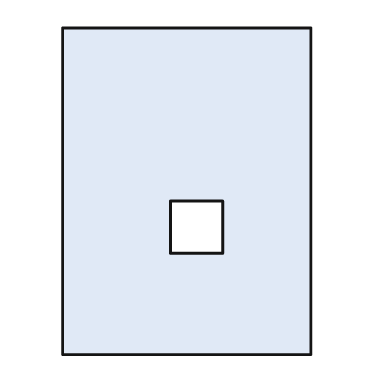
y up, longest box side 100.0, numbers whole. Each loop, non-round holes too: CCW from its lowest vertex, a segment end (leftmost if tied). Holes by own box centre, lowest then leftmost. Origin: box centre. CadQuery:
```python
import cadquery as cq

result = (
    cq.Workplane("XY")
    .moveTo(-38.0, -50.0)
    .lineTo(38.0, -50.0)
    .lineTo(38.0, 50.0)
    .lineTo(-38.0, 50.0)
    .close()
    .moveTo(-5.0, -19.0)
    .lineTo(11.0, -19.0)
    .lineTo(11.0, -3.0)
    .lineTo(-5.0, -3.0)
    .close()
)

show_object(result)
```